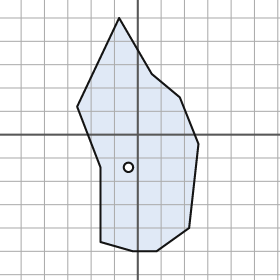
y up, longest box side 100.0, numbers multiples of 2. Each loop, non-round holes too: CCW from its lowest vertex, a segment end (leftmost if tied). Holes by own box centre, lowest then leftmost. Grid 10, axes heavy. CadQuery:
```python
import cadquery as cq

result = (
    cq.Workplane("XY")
    .moveTo(-2.0, -50.0)
    .lineTo(8.0, -50.0)
    .lineTo(22.0, -40.0)
    .lineTo(26.0, -4.0)
    .lineTo(18.0, 16.0)
    .lineTo(6.0, 26.0)
    .lineTo(-8.0, 50.0)
    .lineTo(-26.0, 12.0)
    .lineTo(-16.0, -14.0)
    .lineTo(-16.0, -46.0)
    .close()
    .moveTo(-4.0, -14.0)
    .circle(2.0)
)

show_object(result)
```